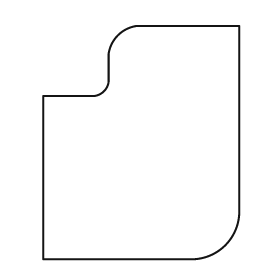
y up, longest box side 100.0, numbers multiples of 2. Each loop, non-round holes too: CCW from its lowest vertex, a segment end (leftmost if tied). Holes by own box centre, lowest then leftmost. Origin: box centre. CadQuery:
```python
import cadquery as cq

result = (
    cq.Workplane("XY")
    .moveTo(-42.0, -50.0)
    .lineTo(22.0, -50.0)
    .threePointArc((36.0, -44.0), (42.0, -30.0))
    .lineTo(42.0, 50.0)
    .lineTo(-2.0, 50.0)
    .threePointArc((-10.0, 46.0), (-14.0, 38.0))
    .lineTo(-14.0, 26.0)
    .threePointArc((-16.0, 22.0), (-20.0, 20.0))
    .lineTo(-42.0, 20.0)
    .close()
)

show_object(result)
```